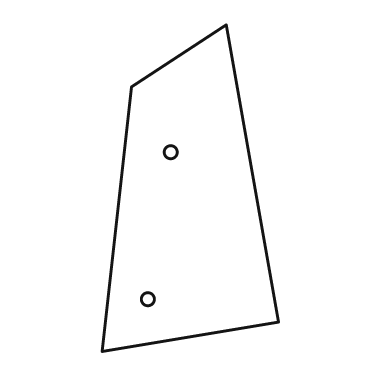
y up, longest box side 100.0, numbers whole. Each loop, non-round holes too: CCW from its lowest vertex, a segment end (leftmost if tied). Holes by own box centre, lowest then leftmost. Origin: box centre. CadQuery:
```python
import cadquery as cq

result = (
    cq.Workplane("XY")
    .moveTo(-27.0, -50.0)
    .lineTo(27.0, -41.0)
    .lineTo(11.0, 50.0)
    .lineTo(-18.0, 31.0)
    .close()
    .moveTo(-13.0, -34.0)
    .circle(2.0)
    .moveTo(-6.0, 11.0)
    .circle(2.0)
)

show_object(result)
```